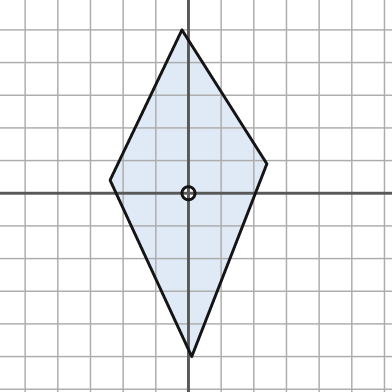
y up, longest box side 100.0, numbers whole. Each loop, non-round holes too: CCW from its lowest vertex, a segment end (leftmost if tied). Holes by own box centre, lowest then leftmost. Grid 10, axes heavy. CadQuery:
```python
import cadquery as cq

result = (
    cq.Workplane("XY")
    .moveTo(1.0, -50.0)
    .lineTo(24.0, 9.0)
    .lineTo(-2.0, 50.0)
    .lineTo(-24.0, 4.0)
    .close()
    .moveTo(0.0, 0.0)
    .circle(2.0)
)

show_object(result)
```